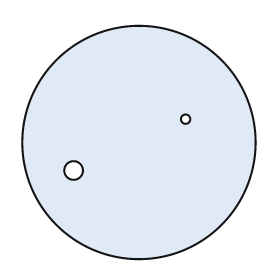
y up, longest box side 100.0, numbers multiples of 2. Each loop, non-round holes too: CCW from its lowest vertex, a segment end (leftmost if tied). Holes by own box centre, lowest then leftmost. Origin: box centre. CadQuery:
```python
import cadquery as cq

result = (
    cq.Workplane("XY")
    .moveTo(0.0, 0.0)
    .circle(50.0)
    .moveTo(-28.0, -12.0)
    .circle(4.0)
    .moveTo(20.0, 10.0)
    .circle(2.0)
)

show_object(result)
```